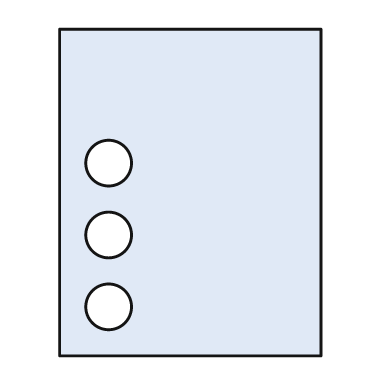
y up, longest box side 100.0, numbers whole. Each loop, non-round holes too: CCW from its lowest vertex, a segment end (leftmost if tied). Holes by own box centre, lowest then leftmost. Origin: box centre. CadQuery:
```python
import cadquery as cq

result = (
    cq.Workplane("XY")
    .moveTo(-40.0, -50.0)
    .lineTo(40.0, -50.0)
    .lineTo(40.0, 50.0)
    .lineTo(-40.0, 50.0)
    .close()
    .moveTo(-25.0, -35.0)
    .circle(7.0)
    .moveTo(-25.0, -13.0)
    .circle(7.0)
    .moveTo(-25.0, 9.0)
    .circle(7.0)
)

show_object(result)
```